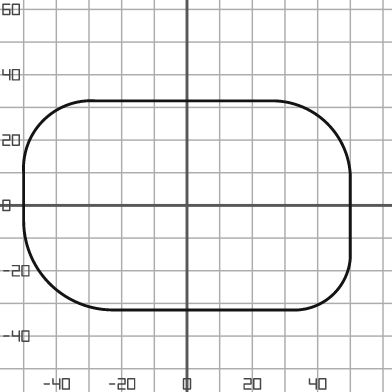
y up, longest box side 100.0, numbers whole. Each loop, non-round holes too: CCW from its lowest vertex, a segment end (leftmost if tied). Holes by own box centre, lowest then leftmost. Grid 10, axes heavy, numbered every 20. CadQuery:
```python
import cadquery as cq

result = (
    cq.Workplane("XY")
    .moveTo(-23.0, -32.0)
    .lineTo(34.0, -32.0)
    .threePointArc((45.0, -27.0), (50.0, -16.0))
    .lineTo(50.0, 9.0)
    .threePointArc((43.0, 25.0), (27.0, 32.0))
    .lineTo(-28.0, 32.0)
    .threePointArc((-44.0, 26.0), (-50.0, 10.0))
    .lineTo(-50.0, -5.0)
    .threePointArc((-42.0, -24.0), (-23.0, -32.0))
    .close()
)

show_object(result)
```